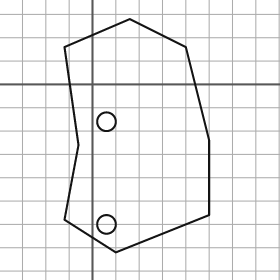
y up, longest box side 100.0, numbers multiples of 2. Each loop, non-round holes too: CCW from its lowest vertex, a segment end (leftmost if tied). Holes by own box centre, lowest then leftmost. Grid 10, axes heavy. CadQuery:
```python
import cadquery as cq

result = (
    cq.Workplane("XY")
    .moveTo(10.0, -72.0)
    .lineTo(50.0, -56.0)
    .lineTo(50.0, -24.0)
    .lineTo(40.0, 16.0)
    .lineTo(16.0, 28.0)
    .lineTo(-12.0, 16.0)
    .lineTo(-6.0, -26.0)
    .lineTo(-12.0, -58.0)
    .close()
    .moveTo(6.0, -60.0)
    .circle(4.0)
    .moveTo(6.0, -16.0)
    .circle(4.0)
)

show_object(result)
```